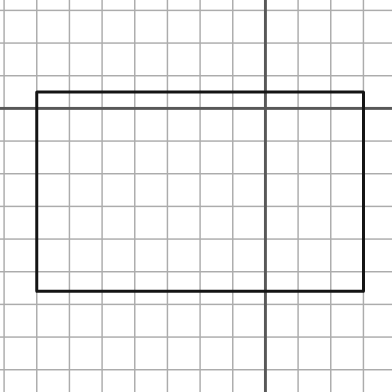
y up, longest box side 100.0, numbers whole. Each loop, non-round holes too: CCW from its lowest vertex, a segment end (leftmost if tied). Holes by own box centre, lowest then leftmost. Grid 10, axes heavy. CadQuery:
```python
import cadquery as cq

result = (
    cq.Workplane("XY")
    .moveTo(-70.0, -56.0)
    .lineTo(30.0, -56.0)
    .lineTo(30.0, 5.0)
    .lineTo(-70.0, 5.0)
    .close()
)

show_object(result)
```